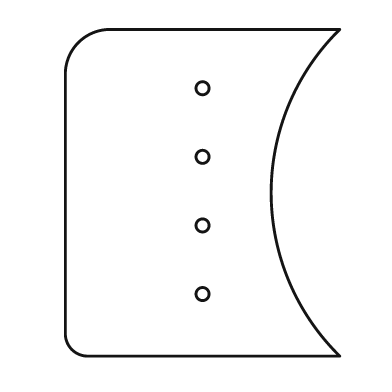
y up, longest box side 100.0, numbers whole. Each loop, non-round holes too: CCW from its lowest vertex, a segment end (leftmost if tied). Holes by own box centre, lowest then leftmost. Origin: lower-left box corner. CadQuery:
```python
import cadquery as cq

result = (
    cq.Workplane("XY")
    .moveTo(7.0, 0.0)
    .lineTo(84.0, 0.0)
    .threePointArc((63.0, 50.0), (84.0, 100.0))
    .lineTo(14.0, 100.0)
    .threePointArc((4.0, 96.0), (0.0, 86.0))
    .lineTo(0.0, 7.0)
    .threePointArc((2.0, 2.0), (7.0, 0.0))
    .close()
    .moveTo(42.0, 19.0)
    .circle(2.0)
    .moveTo(42.0, 40.0)
    .circle(2.0)
    .moveTo(42.0, 61.0)
    .circle(2.0)
    .moveTo(42.0, 82.0)
    .circle(2.0)
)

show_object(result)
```